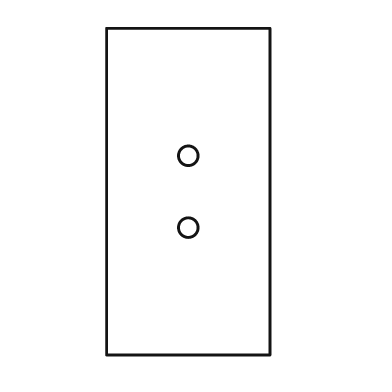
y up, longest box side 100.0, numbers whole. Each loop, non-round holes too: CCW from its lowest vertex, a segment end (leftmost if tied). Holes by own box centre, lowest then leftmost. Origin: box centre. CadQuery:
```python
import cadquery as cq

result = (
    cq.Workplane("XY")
    .moveTo(-25.0, -50.0)
    .lineTo(25.0, -50.0)
    .lineTo(25.0, 50.0)
    .lineTo(-25.0, 50.0)
    .close()
    .moveTo(0.0, -11.0)
    .circle(3.0)
    .moveTo(0.0, 11.0)
    .circle(3.0)
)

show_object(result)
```